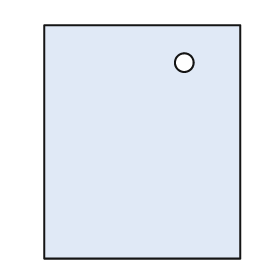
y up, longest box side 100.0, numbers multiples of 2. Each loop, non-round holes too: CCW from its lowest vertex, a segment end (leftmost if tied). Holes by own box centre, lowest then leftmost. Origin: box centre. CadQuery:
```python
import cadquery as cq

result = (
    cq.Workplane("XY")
    .moveTo(-42.0, -50.0)
    .lineTo(42.0, -50.0)
    .lineTo(42.0, 50.0)
    .lineTo(-42.0, 50.0)
    .close()
    .moveTo(18.0, 34.0)
    .circle(4.0)
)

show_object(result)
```